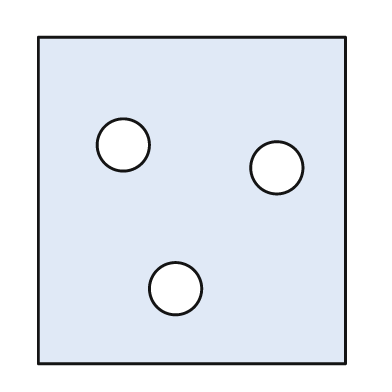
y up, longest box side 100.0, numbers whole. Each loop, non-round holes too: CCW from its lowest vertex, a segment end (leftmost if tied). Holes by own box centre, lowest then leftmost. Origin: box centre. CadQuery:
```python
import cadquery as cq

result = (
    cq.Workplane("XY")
    .moveTo(-47.0, -50.0)
    .lineTo(47.0, -50.0)
    .lineTo(47.0, 50.0)
    .lineTo(-47.0, 50.0)
    .close()
    .moveTo(-5.0, -27.0)
    .circle(8.0)
    .moveTo(26.0, 10.0)
    .circle(8.0)
    .moveTo(-21.0, 17.0)
    .circle(8.0)
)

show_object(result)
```